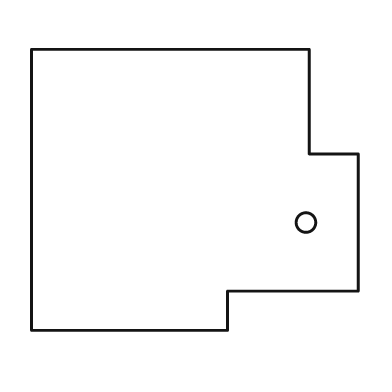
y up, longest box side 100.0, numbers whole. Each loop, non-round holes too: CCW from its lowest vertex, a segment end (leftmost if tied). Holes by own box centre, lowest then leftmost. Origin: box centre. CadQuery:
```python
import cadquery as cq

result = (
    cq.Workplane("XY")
    .moveTo(-50.0, -43.0)
    .lineTo(10.0, -43.0)
    .lineTo(10.0, -31.0)
    .lineTo(50.0, -31.0)
    .lineTo(50.0, 11.0)
    .lineTo(35.0, 11.0)
    .lineTo(35.0, 43.0)
    .lineTo(-50.0, 43.0)
    .close()
    .moveTo(34.0, -10.0)
    .circle(3.0)
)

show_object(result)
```